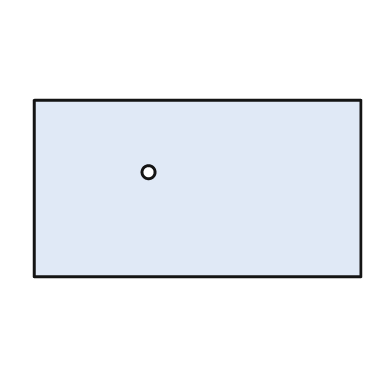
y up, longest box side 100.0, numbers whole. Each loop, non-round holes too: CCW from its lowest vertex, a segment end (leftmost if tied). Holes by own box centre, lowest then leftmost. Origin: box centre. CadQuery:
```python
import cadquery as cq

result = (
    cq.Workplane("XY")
    .moveTo(-50.0, -27.0)
    .lineTo(50.0, -27.0)
    .lineTo(50.0, 27.0)
    .lineTo(-50.0, 27.0)
    .close()
    .moveTo(-15.0, 5.0)
    .circle(2.0)
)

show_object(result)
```